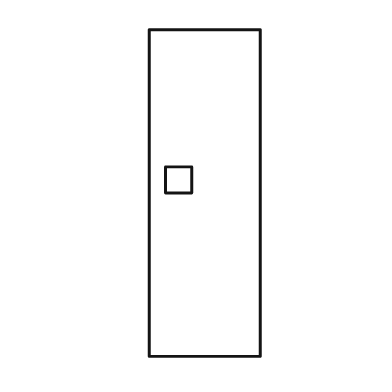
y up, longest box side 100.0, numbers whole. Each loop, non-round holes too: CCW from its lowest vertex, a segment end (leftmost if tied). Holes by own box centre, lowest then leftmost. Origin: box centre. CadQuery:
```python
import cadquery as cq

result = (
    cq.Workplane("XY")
    .moveTo(-17.0, -50.0)
    .lineTo(17.0, -50.0)
    .lineTo(17.0, 50.0)
    .lineTo(-17.0, 50.0)
    .close()
    .moveTo(-12.0, 0.0)
    .lineTo(-4.0, 0.0)
    .lineTo(-4.0, 8.0)
    .lineTo(-12.0, 8.0)
    .close()
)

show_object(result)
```